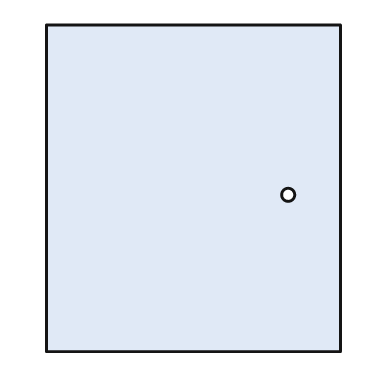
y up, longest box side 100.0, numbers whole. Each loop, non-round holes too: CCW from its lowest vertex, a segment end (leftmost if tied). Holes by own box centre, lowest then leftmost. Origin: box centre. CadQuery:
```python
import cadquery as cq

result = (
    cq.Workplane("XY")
    .moveTo(-45.0, -50.0)
    .lineTo(45.0, -50.0)
    .lineTo(45.0, 50.0)
    .lineTo(-45.0, 50.0)
    .close()
    .moveTo(29.0, -2.0)
    .circle(2.0)
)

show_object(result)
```